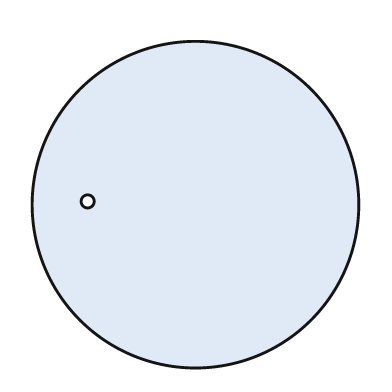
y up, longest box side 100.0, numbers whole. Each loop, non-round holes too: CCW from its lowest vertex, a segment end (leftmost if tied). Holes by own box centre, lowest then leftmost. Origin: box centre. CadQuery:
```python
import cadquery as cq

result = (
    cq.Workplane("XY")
    .moveTo(0.0, 0.0)
    .circle(50.0)
    .moveTo(-33.0, 1.0)
    .circle(2.0)
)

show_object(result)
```